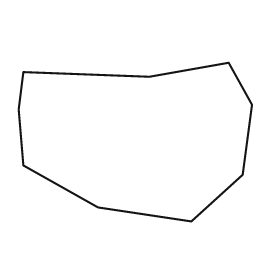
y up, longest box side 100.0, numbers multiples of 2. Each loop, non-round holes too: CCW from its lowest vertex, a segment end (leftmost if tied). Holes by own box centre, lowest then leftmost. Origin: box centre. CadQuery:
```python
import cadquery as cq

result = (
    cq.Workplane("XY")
    .moveTo(24.0, -34.0)
    .lineTo(46.0, -14.0)
    .lineTo(50.0, 16.0)
    .lineTo(40.0, 34.0)
    .lineTo(6.0, 28.0)
    .lineTo(-48.0, 30.0)
    .lineTo(-50.0, 14.0)
    .lineTo(-48.0, -10.0)
    .lineTo(-16.0, -28.0)
    .close()
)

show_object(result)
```